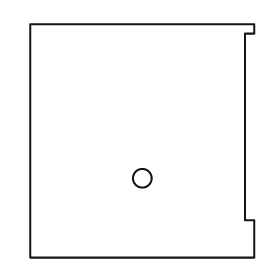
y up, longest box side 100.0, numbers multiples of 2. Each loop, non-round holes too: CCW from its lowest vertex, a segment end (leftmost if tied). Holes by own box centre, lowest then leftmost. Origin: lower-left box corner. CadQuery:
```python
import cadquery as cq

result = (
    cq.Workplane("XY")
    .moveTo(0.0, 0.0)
    .lineTo(96.0, 0.0)
    .lineTo(96.0, 16.0)
    .lineTo(92.0, 16.0)
    .lineTo(92.0, 96.0)
    .lineTo(96.0, 96.0)
    .lineTo(96.0, 100.0)
    .lineTo(0.0, 100.0)
    .close()
    .moveTo(48.0, 34.0)
    .circle(4.0)
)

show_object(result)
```